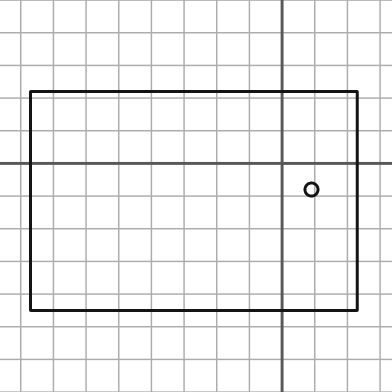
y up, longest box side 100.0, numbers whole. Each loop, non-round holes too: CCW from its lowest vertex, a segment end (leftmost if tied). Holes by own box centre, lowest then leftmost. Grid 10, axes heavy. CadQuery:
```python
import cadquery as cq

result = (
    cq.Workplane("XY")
    .moveTo(-77.0, -45.0)
    .lineTo(23.0, -45.0)
    .lineTo(23.0, 22.0)
    .lineTo(-77.0, 22.0)
    .close()
    .moveTo(9.0, -8.0)
    .circle(2.0)
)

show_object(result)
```